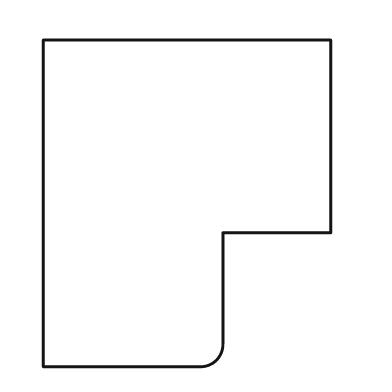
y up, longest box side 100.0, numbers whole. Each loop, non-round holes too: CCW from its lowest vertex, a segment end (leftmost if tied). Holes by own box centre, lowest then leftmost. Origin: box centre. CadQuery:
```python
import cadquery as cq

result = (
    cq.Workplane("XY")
    .moveTo(-44.0, -50.0)
    .lineTo(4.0, -50.0)
    .threePointArc((9.0, -48.0), (11.0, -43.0))
    .lineTo(11.0, -9.0)
    .lineTo(44.0, -9.0)
    .lineTo(44.0, 50.0)
    .lineTo(-44.0, 50.0)
    .close()
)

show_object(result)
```